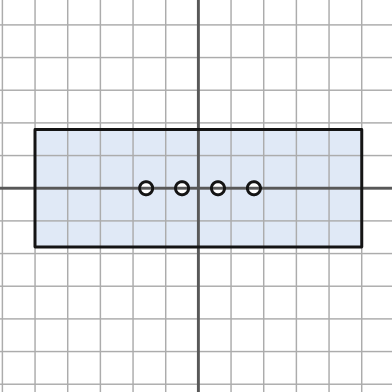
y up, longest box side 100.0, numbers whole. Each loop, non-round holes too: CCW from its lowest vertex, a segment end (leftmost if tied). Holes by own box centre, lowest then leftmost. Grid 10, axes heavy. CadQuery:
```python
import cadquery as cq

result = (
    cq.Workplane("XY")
    .moveTo(-50.0, -18.0)
    .lineTo(50.0, -18.0)
    .lineTo(50.0, 18.0)
    .lineTo(-50.0, 18.0)
    .close()
    .moveTo(-16.0, 0.0)
    .circle(2.0)
    .moveTo(-5.0, 0.0)
    .circle(2.0)
    .moveTo(6.0, 0.0)
    .circle(2.0)
    .moveTo(17.0, 0.0)
    .circle(2.0)
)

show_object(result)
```